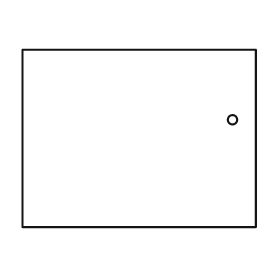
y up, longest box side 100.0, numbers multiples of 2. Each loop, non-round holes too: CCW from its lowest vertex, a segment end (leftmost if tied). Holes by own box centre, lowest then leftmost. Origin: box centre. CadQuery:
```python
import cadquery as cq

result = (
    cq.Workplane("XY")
    .moveTo(-50.0, -38.0)
    .lineTo(50.0, -38.0)
    .lineTo(50.0, 38.0)
    .lineTo(-50.0, 38.0)
    .close()
    .moveTo(40.0, 8.0)
    .circle(2.0)
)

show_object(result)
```